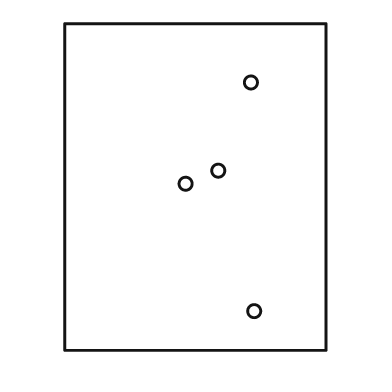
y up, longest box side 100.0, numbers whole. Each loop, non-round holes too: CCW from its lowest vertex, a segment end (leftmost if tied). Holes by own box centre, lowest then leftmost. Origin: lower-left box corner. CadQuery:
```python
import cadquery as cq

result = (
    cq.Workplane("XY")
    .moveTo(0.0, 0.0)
    .lineTo(80.0, 0.0)
    .lineTo(80.0, 100.0)
    .lineTo(0.0, 100.0)
    .close()
    .moveTo(58.0, 12.0)
    .circle(2.0)
    .moveTo(37.0, 51.0)
    .circle(2.0)
    .moveTo(47.0, 55.0)
    .circle(2.0)
    .moveTo(57.0, 82.0)
    .circle(2.0)
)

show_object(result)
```